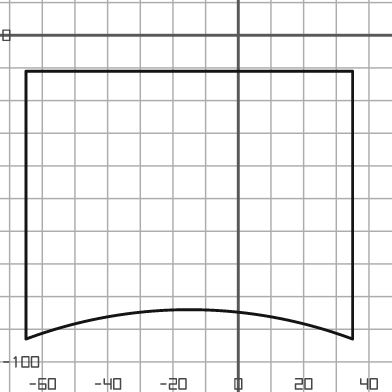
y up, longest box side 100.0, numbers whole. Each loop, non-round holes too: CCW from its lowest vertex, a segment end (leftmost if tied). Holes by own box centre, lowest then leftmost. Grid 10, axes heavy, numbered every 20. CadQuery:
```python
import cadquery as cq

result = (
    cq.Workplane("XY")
    .moveTo(-65.0, -93.0)
    .threePointArc((-15.0, -84.0), (35.0, -93.0))
    .lineTo(35.0, -11.0)
    .lineTo(-65.0, -11.0)
    .close()
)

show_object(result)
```